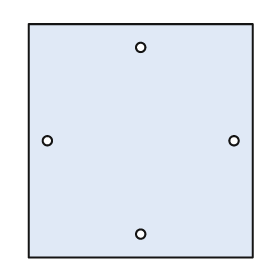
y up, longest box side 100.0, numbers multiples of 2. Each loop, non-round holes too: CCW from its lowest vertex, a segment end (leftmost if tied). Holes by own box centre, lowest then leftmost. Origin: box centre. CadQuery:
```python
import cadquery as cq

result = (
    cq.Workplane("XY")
    .moveTo(-48.0, -50.0)
    .lineTo(48.0, -50.0)
    .lineTo(48.0, 50.0)
    .lineTo(-48.0, 50.0)
    .close()
    .moveTo(0.0, -40.0)
    .circle(2.0)
    .moveTo(-40.0, 0.0)
    .circle(2.0)
    .moveTo(40.0, 0.0)
    .circle(2.0)
    .moveTo(0.0, 40.0)
    .circle(2.0)
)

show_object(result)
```